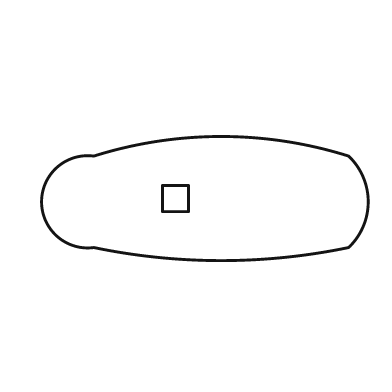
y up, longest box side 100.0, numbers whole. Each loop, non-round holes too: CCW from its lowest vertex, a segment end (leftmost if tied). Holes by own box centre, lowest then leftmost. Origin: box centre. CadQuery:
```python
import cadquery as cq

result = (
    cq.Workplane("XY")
    .moveTo(-34.0, -15.0)
    .threePointArc((5.0, -19.0), (44.0, -15.0))
    .threePointArc((50.0, -1.0), (44.0, 13.0))
    .threePointArc((5.0, 19.0), (-34.0, 13.0))
    .threePointArc((-50.0, -1.0), (-34.0, -15.0))
    .close()
    .moveTo(-13.0, -4.0)
    .lineTo(-5.0, -4.0)
    .lineTo(-5.0, 4.0)
    .lineTo(-13.0, 4.0)
    .close()
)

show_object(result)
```